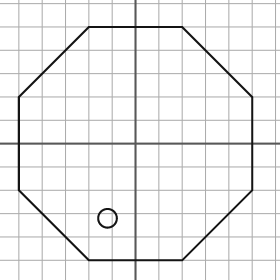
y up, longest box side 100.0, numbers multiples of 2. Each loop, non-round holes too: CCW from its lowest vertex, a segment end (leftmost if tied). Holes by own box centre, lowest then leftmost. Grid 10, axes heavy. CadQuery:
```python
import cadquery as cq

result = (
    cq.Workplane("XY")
    .moveTo(-20.0, -50.0)
    .lineTo(20.0, -50.0)
    .lineTo(50.0, -20.0)
    .lineTo(50.0, 20.0)
    .lineTo(20.0, 50.0)
    .lineTo(-20.0, 50.0)
    .lineTo(-50.0, 20.0)
    .lineTo(-50.0, -20.0)
    .close()
    .moveTo(-12.0, -32.0)
    .circle(4.0)
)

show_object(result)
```